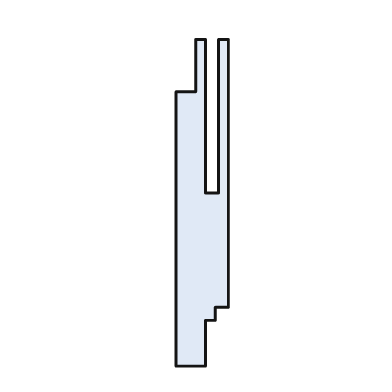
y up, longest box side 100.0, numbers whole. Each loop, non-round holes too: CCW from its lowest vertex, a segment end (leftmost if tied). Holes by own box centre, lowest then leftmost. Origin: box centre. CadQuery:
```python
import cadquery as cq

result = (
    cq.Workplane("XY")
    .moveTo(-8.0, -50.0)
    .lineTo(1.0, -50.0)
    .lineTo(1.0, -36.0)
    .lineTo(4.0, -36.0)
    .lineTo(4.0, -32.0)
    .lineTo(8.0, -32.0)
    .lineTo(8.0, 50.0)
    .lineTo(5.0, 50.0)
    .lineTo(5.0, 3.0)
    .lineTo(1.0, 3.0)
    .lineTo(1.0, 50.0)
    .lineTo(-2.0, 50.0)
    .lineTo(-2.0, 34.0)
    .lineTo(-8.0, 34.0)
    .close()
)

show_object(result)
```